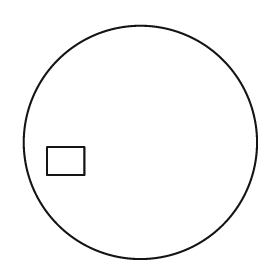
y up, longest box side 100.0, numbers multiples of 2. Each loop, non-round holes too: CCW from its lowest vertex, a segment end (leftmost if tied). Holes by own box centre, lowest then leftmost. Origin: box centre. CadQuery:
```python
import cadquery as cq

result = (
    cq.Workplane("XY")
    .moveTo(0.0, 0.0)
    .circle(50.0)
    .moveTo(-40.0, -14.0)
    .lineTo(-24.0, -14.0)
    .lineTo(-24.0, -2.0)
    .lineTo(-40.0, -2.0)
    .close()
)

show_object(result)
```